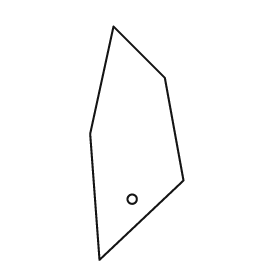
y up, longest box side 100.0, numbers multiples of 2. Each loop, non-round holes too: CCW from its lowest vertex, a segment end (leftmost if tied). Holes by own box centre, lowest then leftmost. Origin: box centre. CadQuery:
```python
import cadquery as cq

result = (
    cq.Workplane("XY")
    .moveTo(-16.0, -50.0)
    .lineTo(20.0, -16.0)
    .lineTo(12.0, 28.0)
    .lineTo(-10.0, 50.0)
    .lineTo(-20.0, 4.0)
    .close()
    .moveTo(-2.0, -24.0)
    .circle(2.0)
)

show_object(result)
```